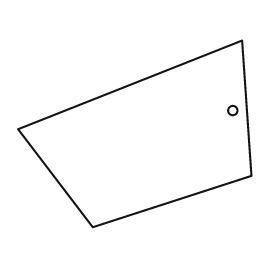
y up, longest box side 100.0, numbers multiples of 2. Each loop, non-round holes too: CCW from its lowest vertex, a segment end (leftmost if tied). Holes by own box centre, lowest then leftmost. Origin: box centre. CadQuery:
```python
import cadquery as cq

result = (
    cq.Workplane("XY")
    .moveTo(-18.0, -40.0)
    .lineTo(50.0, -18.0)
    .lineTo(46.0, 40.0)
    .lineTo(-50.0, 2.0)
    .close()
    .moveTo(42.0, 10.0)
    .circle(2.0)
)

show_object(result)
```